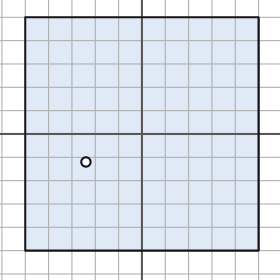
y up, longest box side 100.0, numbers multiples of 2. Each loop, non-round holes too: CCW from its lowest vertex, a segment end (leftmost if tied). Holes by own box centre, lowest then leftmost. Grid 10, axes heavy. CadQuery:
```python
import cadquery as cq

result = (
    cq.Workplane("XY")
    .moveTo(-50.0, -50.0)
    .lineTo(50.0, -50.0)
    .lineTo(50.0, 50.0)
    .lineTo(-50.0, 50.0)
    .close()
    .moveTo(-24.0, -12.0)
    .circle(2.0)
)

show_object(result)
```